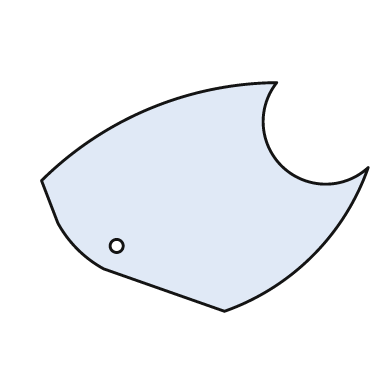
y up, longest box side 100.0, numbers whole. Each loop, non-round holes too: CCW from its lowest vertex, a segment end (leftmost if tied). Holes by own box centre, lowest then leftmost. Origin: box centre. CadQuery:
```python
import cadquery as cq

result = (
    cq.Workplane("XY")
    .moveTo(6.0, -35.0)
    .threePointArc((33.0, -18.0), (50.0, 9.0))
    .threePointArc((24.0, 9.0), (22.0, 35.0))
    .threePointArc((-17.0, 27.0), (-50.0, 5.0))
    .lineTo(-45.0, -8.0)
    .threePointArc((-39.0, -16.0), (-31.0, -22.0))
    .close()
    .moveTo(-27.0, -15.0)
    .circle(2.0)
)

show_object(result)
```